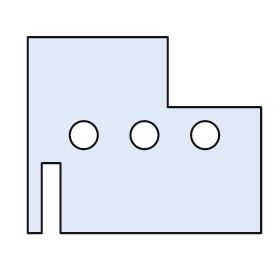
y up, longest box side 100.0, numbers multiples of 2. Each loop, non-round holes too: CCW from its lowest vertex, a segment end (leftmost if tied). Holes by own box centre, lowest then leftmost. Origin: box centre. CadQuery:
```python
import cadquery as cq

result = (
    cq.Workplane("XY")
    .moveTo(-50.0, -42.0)
    .lineTo(-44.0, -42.0)
    .lineTo(-44.0, -12.0)
    .lineTo(-36.0, -12.0)
    .lineTo(-36.0, -42.0)
    .lineTo(50.0, -42.0)
    .lineTo(50.0, 12.0)
    .lineTo(10.0, 12.0)
    .lineTo(10.0, 42.0)
    .lineTo(-50.0, 42.0)
    .close()
    .moveTo(-26.0, 0.0)
    .circle(6.0)
    .moveTo(0.0, 0.0)
    .circle(6.0)
    .moveTo(26.0, 0.0)
    .circle(6.0)
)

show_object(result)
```